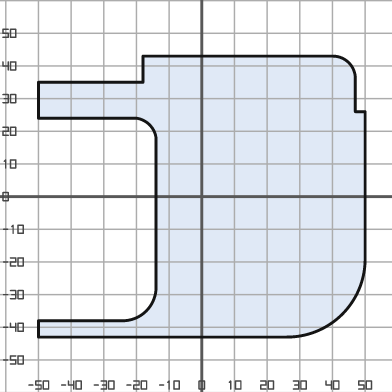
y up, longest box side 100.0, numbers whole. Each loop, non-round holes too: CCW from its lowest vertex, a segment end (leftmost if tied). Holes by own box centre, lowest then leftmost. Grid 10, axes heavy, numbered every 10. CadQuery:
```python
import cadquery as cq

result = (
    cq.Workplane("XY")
    .moveTo(-50.0, -43.0)
    .lineTo(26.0, -43.0)
    .threePointArc((43.0, -36.0), (50.0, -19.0))
    .lineTo(50.0, 26.0)
    .lineTo(47.0, 26.0)
    .lineTo(47.0, 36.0)
    .threePointArc((45.0, 41.0), (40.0, 43.0))
    .lineTo(-18.0, 43.0)
    .lineTo(-18.0, 35.0)
    .lineTo(-50.0, 35.0)
    .lineTo(-50.0, 24.0)
    .lineTo(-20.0, 24.0)
    .threePointArc((-16.0, 22.0), (-14.0, 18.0))
    .lineTo(-14.0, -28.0)
    .threePointArc((-17.0, -35.0), (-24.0, -38.0))
    .lineTo(-50.0, -38.0)
    .close()
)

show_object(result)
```